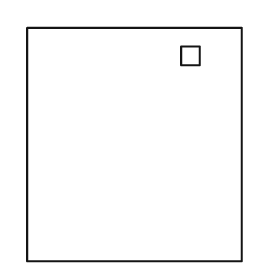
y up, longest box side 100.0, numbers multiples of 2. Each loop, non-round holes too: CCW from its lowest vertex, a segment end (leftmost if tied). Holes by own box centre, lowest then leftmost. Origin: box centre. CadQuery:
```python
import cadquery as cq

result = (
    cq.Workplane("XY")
    .moveTo(-46.0, -50.0)
    .lineTo(46.0, -50.0)
    .lineTo(46.0, 50.0)
    .lineTo(-46.0, 50.0)
    .close()
    .moveTo(20.0, 34.0)
    .lineTo(28.0, 34.0)
    .lineTo(28.0, 42.0)
    .lineTo(20.0, 42.0)
    .close()
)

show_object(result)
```